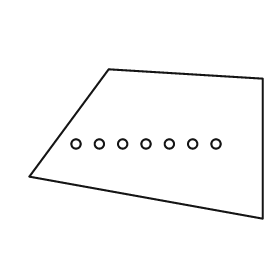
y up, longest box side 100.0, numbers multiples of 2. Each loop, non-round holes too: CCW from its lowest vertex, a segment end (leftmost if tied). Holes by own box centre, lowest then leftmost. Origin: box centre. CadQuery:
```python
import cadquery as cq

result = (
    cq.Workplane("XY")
    .moveTo(50.0, -32.0)
    .lineTo(50.0, 28.0)
    .lineTo(-16.0, 32.0)
    .lineTo(-50.0, -14.0)
    .close()
    .moveTo(-30.0, 0.0)
    .circle(2.0)
    .moveTo(-20.0, 0.0)
    .circle(2.0)
    .moveTo(-10.0, 0.0)
    .circle(2.0)
    .moveTo(0.0, 0.0)
    .circle(2.0)
    .moveTo(10.0, 0.0)
    .circle(2.0)
    .moveTo(20.0, 0.0)
    .circle(2.0)
    .moveTo(30.0, 0.0)
    .circle(2.0)
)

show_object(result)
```